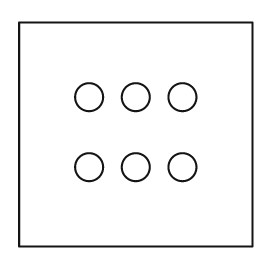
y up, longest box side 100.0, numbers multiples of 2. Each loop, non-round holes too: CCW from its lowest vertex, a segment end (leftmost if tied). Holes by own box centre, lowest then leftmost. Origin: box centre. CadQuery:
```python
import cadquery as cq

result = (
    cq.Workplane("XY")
    .moveTo(-50.0, -48.0)
    .lineTo(50.0, -48.0)
    .lineTo(50.0, 48.0)
    .lineTo(-50.0, 48.0)
    .close()
    .moveTo(-20.0, -14.0)
    .circle(6.0)
    .moveTo(0.0, -14.0)
    .circle(6.0)
    .moveTo(20.0, -14.0)
    .circle(6.0)
    .moveTo(-20.0, 16.0)
    .circle(6.0)
    .moveTo(0.0, 16.0)
    .circle(6.0)
    .moveTo(20.0, 16.0)
    .circle(6.0)
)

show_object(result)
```